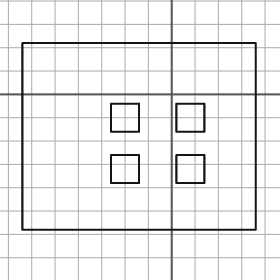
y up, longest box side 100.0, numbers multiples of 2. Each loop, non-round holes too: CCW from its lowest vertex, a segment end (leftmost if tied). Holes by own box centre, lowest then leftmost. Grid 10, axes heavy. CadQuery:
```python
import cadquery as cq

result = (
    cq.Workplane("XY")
    .moveTo(-64.0, -58.0)
    .lineTo(36.0, -58.0)
    .lineTo(36.0, 22.0)
    .lineTo(-64.0, 22.0)
    .close()
    .moveTo(-26.0, -38.0)
    .lineTo(-14.0, -38.0)
    .lineTo(-14.0, -26.0)
    .lineTo(-26.0, -26.0)
    .close()
    .moveTo(2.0, -38.0)
    .lineTo(14.0, -38.0)
    .lineTo(14.0, -26.0)
    .lineTo(2.0, -26.0)
    .close()
    .moveTo(-26.0, -16.0)
    .lineTo(-14.0, -16.0)
    .lineTo(-14.0, -4.0)
    .lineTo(-26.0, -4.0)
    .close()
    .moveTo(2.0, -16.0)
    .lineTo(14.0, -16.0)
    .lineTo(14.0, -4.0)
    .lineTo(2.0, -4.0)
    .close()
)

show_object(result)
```